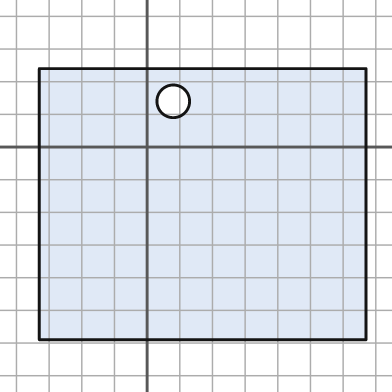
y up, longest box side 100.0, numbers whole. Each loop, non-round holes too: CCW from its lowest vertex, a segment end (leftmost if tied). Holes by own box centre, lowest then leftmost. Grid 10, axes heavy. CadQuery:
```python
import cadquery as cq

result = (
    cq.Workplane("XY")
    .moveTo(-33.0, -59.0)
    .lineTo(67.0, -59.0)
    .lineTo(67.0, 24.0)
    .lineTo(-33.0, 24.0)
    .close()
    .moveTo(8.0, 14.0)
    .circle(5.0)
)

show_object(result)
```